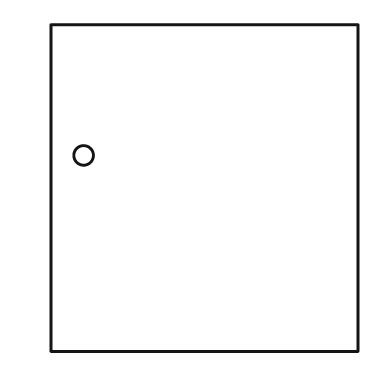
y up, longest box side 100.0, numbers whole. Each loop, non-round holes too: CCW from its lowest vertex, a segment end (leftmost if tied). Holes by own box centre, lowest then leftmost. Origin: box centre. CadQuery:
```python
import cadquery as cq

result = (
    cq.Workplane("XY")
    .moveTo(-47.0, -50.0)
    .lineTo(47.0, -50.0)
    .lineTo(47.0, 50.0)
    .lineTo(-47.0, 50.0)
    .close()
    .moveTo(-37.0, 10.0)
    .circle(3.0)
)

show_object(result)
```